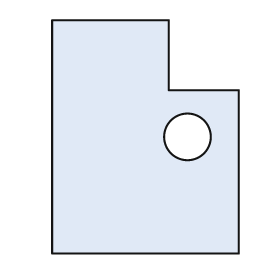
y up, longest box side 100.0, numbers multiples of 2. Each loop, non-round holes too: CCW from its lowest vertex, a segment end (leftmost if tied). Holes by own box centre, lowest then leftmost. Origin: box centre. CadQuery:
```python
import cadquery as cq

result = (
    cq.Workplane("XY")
    .moveTo(-40.0, -50.0)
    .lineTo(40.0, -50.0)
    .lineTo(40.0, 20.0)
    .lineTo(10.0, 20.0)
    .lineTo(10.0, 50.0)
    .lineTo(-40.0, 50.0)
    .close()
    .moveTo(18.0, 0.0)
    .circle(10.0)
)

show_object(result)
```